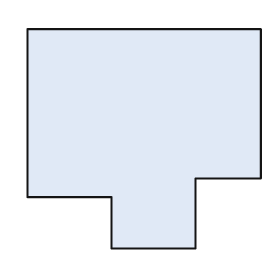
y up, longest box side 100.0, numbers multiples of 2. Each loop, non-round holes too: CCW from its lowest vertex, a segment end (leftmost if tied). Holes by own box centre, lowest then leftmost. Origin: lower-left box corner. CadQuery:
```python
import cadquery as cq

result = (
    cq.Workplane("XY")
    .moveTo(36.0, 0.0)
    .lineTo(72.0, 0.0)
    .lineTo(72.0, 30.0)
    .lineTo(100.0, 30.0)
    .lineTo(100.0, 94.0)
    .lineTo(0.0, 94.0)
    .lineTo(0.0, 22.0)
    .lineTo(36.0, 22.0)
    .close()
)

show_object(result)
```